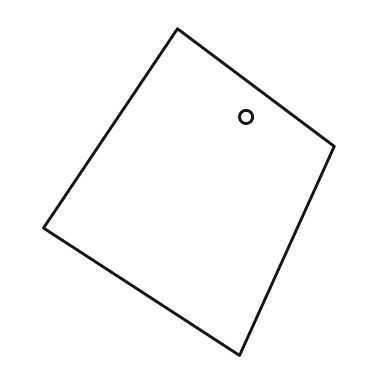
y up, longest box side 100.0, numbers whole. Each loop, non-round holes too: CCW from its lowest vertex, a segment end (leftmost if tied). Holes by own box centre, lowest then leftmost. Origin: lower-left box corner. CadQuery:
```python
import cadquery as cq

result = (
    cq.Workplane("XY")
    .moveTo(60.0, 0.0)
    .lineTo(89.0, 64.0)
    .lineTo(41.0, 100.0)
    .lineTo(0.0, 39.0)
    .close()
    .moveTo(62.0, 73.0)
    .circle(2.0)
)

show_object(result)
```